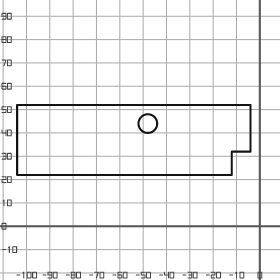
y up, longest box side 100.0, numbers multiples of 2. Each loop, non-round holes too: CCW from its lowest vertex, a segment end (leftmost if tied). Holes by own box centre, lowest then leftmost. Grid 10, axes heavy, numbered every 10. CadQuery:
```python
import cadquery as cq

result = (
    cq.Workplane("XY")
    .moveTo(-104.0, 22.0)
    .lineTo(-12.0, 22.0)
    .lineTo(-12.0, 32.0)
    .lineTo(-4.0, 32.0)
    .lineTo(-4.0, 52.0)
    .lineTo(-104.0, 52.0)
    .close()
    .moveTo(-48.0, 44.0)
    .circle(4.0)
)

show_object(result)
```